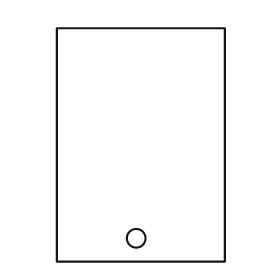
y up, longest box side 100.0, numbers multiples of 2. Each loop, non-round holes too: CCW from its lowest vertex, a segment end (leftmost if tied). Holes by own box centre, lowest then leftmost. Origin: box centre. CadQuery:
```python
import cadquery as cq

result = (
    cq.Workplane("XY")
    .moveTo(-36.0, -50.0)
    .lineTo(36.0, -50.0)
    .lineTo(36.0, 50.0)
    .lineTo(-36.0, 50.0)
    .close()
    .moveTo(-2.0, -40.0)
    .circle(4.0)
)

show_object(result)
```